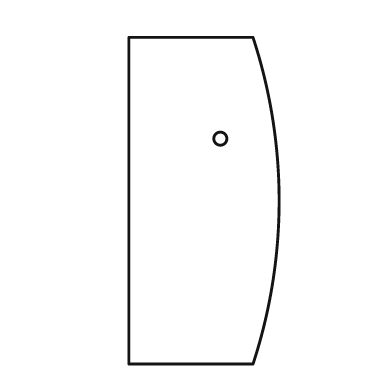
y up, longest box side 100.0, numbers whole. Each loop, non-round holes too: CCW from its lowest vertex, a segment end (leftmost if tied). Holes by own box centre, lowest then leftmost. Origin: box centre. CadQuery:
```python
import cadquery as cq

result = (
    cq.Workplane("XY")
    .moveTo(-23.0, -50.0)
    .lineTo(15.0, -50.0)
    .threePointArc((23.0, 0.0), (15.0, 50.0))
    .lineTo(-23.0, 50.0)
    .close()
    .moveTo(5.0, 19.0)
    .circle(2.0)
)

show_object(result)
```